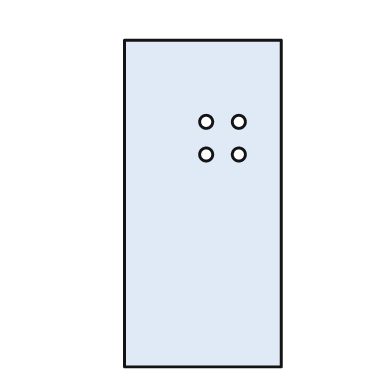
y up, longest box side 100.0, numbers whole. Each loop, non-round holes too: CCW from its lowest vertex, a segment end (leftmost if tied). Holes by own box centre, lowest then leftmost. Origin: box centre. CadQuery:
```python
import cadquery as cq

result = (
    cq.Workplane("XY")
    .moveTo(-24.0, -50.0)
    .lineTo(24.0, -50.0)
    .lineTo(24.0, 50.0)
    .lineTo(-24.0, 50.0)
    .close()
    .moveTo(1.0, 15.0)
    .circle(2.0)
    .moveTo(11.0, 15.0)
    .circle(2.0)
    .moveTo(1.0, 25.0)
    .circle(2.0)
    .moveTo(11.0, 25.0)
    .circle(2.0)
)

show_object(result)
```